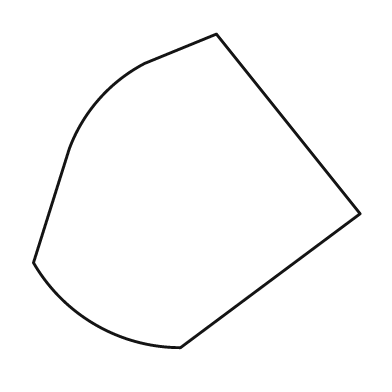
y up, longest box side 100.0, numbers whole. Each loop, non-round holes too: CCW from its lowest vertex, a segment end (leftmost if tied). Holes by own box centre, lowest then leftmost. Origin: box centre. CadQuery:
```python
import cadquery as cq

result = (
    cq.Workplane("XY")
    .moveTo(-5.0, -48.0)
    .lineTo(50.0, -7.0)
    .lineTo(6.0, 48.0)
    .lineTo(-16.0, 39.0)
    .threePointArc((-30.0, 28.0), (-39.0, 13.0))
    .lineTo(-50.0, -22.0)
    .threePointArc((-31.0, -41.0), (-5.0, -48.0))
    .close()
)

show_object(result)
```